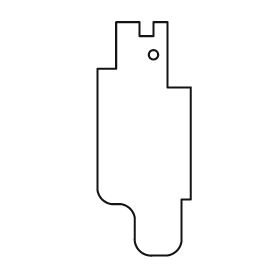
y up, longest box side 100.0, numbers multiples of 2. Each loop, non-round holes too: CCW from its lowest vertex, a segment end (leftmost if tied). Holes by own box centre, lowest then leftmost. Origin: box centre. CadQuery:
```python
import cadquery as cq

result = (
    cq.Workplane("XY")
    .moveTo(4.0, -50.0)
    .lineTo(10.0, -50.0)
    .threePointArc((14.0, -48.0), (16.0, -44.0))
    .lineTo(16.0, -26.0)
    .lineTo(20.0, -26.0)
    .lineTo(20.0, 22.0)
    .lineTo(10.0, 22.0)
    .lineTo(10.0, 50.0)
    .lineTo(4.0, 50.0)
    .lineTo(4.0, 44.0)
    .lineTo(-2.0, 44.0)
    .lineTo(-2.0, 50.0)
    .lineTo(-12.0, 50.0)
    .lineTo(-12.0, 30.0)
    .lineTo(-20.0, 30.0)
    .lineTo(-20.0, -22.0)
    .threePointArc((-18.0, -26.0), (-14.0, -28.0))
    .lineTo(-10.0, -28.0)
    .threePointArc((-6.0, -30.0), (-4.0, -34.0))
    .lineTo(-4.0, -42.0)
    .threePointArc((-2.0, -48.0), (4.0, -50.0))
    .close()
    .moveTo(4.0, 36.0)
    .circle(2.0)
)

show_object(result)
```